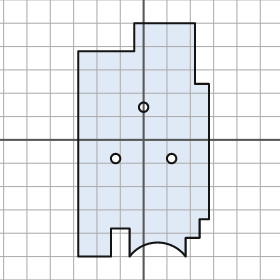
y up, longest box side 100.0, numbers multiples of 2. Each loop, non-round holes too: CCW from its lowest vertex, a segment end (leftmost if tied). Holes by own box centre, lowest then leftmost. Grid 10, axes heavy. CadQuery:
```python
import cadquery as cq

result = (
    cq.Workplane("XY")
    .moveTo(-28.0, -50.0)
    .lineTo(-14.0, -50.0)
    .lineTo(-14.0, -38.0)
    .lineTo(-6.0, -38.0)
    .lineTo(-6.0, -50.0)
    .threePointArc((6.0, -44.0), (18.0, -50.0))
    .lineTo(18.0, -42.0)
    .lineTo(24.0, -42.0)
    .lineTo(24.0, -34.0)
    .lineTo(28.0, -34.0)
    .lineTo(28.0, 24.0)
    .lineTo(22.0, 24.0)
    .lineTo(22.0, 50.0)
    .lineTo(-4.0, 50.0)
    .lineTo(-4.0, 38.0)
    .lineTo(-28.0, 38.0)
    .close()
    .moveTo(-12.0, -8.0)
    .circle(2.0)
    .moveTo(12.0, -8.0)
    .circle(2.0)
    .moveTo(0.0, 14.0)
    .circle(2.0)
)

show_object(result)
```